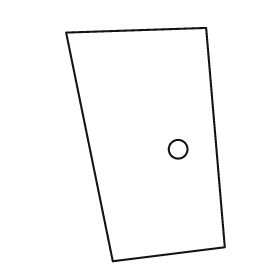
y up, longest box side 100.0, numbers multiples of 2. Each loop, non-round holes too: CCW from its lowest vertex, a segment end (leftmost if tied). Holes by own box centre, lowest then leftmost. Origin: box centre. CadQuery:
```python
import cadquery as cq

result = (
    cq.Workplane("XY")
    .moveTo(-14.0, -50.0)
    .lineTo(34.0, -44.0)
    .lineTo(26.0, 50.0)
    .lineTo(-34.0, 48.0)
    .close()
    .moveTo(14.0, -2.0)
    .circle(4.0)
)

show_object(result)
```